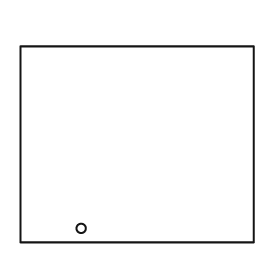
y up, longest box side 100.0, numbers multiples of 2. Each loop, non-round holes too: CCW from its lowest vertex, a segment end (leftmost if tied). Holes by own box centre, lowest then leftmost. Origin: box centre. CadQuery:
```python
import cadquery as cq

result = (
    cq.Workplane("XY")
    .moveTo(-50.0, -42.0)
    .lineTo(50.0, -42.0)
    .lineTo(50.0, 42.0)
    .lineTo(-50.0, 42.0)
    .close()
    .moveTo(-24.0, -36.0)
    .circle(2.0)
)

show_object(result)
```